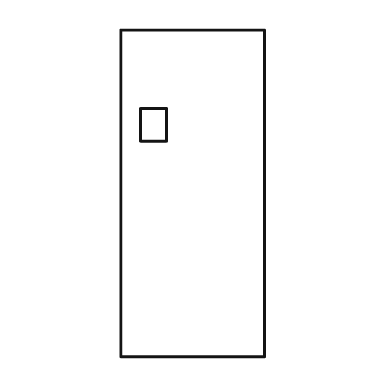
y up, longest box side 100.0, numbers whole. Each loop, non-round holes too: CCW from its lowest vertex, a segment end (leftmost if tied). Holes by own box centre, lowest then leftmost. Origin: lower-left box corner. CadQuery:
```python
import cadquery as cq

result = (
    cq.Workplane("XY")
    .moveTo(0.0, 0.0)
    .lineTo(44.0, 0.0)
    .lineTo(44.0, 100.0)
    .lineTo(0.0, 100.0)
    .close()
    .moveTo(6.0, 66.0)
    .lineTo(14.0, 66.0)
    .lineTo(14.0, 76.0)
    .lineTo(6.0, 76.0)
    .close()
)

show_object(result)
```